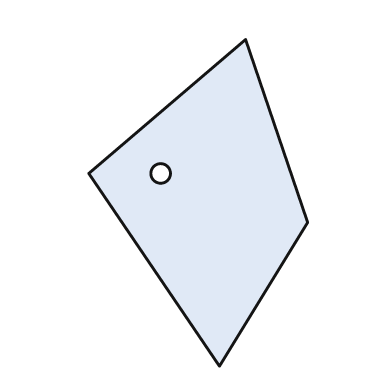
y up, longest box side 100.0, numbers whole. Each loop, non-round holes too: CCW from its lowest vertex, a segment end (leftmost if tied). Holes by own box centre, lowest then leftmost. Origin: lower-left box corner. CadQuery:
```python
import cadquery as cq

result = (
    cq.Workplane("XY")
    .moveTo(40.0, 0.0)
    .lineTo(67.0, 44.0)
    .lineTo(48.0, 100.0)
    .lineTo(0.0, 59.0)
    .close()
    .moveTo(22.0, 59.0)
    .circle(3.0)
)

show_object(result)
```